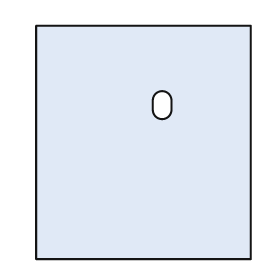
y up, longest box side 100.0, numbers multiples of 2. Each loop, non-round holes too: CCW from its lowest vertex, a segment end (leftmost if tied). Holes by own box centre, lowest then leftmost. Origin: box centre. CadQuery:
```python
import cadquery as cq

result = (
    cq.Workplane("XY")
    .moveTo(-46.0, -50.0)
    .lineTo(46.0, -50.0)
    .lineTo(46.0, 50.0)
    .lineTo(-46.0, 50.0)
    .close()
    .moveTo(4.0, 14.0)
    .threePointArc((8.0, 10.0), (12.0, 14.0))
    .lineTo(12.0, 18.0)
    .threePointArc((8.0, 22.0), (4.0, 18.0))
    .close()
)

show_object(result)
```